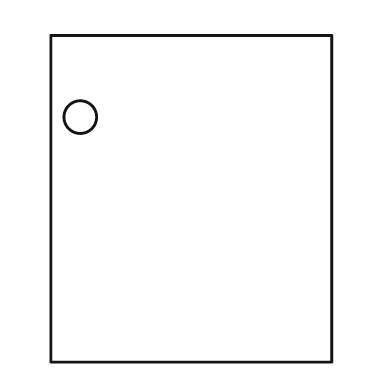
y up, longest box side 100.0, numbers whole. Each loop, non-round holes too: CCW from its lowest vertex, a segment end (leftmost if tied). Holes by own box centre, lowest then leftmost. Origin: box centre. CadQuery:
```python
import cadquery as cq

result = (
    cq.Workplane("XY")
    .moveTo(-43.0, -50.0)
    .lineTo(43.0, -50.0)
    .lineTo(43.0, 50.0)
    .lineTo(-43.0, 50.0)
    .close()
    .moveTo(-34.0, 25.0)
    .circle(5.0)
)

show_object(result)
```